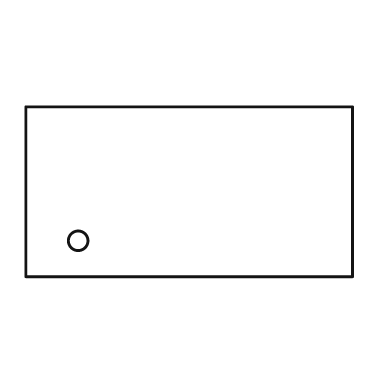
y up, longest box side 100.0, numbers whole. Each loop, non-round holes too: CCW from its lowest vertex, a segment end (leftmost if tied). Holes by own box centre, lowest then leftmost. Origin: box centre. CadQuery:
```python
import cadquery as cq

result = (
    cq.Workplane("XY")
    .moveTo(-50.0, -26.0)
    .lineTo(50.0, -26.0)
    .lineTo(50.0, 26.0)
    .lineTo(-50.0, 26.0)
    .close()
    .moveTo(-34.0, -15.0)
    .circle(3.0)
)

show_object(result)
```